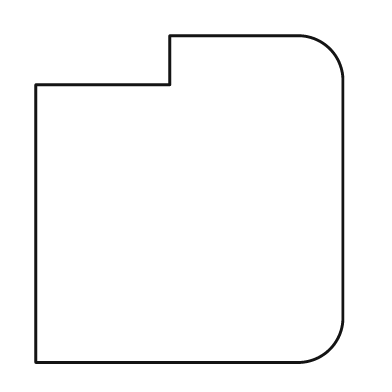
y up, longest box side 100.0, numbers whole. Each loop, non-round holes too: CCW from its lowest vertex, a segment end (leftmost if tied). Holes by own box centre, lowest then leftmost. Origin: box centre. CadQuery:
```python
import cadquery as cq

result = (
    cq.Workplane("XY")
    .moveTo(-47.0, -50.0)
    .lineTo(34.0, -50.0)
    .threePointArc((43.0, -46.0), (47.0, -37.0))
    .lineTo(47.0, 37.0)
    .threePointArc((43.0, 46.0), (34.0, 50.0))
    .lineTo(-6.0, 50.0)
    .lineTo(-6.0, 35.0)
    .lineTo(-47.0, 35.0)
    .close()
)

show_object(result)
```